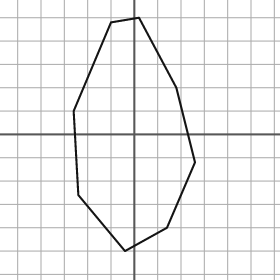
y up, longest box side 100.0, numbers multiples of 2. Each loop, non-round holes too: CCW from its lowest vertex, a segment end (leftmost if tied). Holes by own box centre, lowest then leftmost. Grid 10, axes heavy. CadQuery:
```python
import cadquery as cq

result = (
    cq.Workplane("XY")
    .moveTo(-4.0, -50.0)
    .lineTo(14.0, -40.0)
    .lineTo(26.0, -12.0)
    .lineTo(18.0, 20.0)
    .lineTo(2.0, 50.0)
    .lineTo(-10.0, 48.0)
    .lineTo(-26.0, 10.0)
    .lineTo(-24.0, -26.0)
    .close()
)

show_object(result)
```